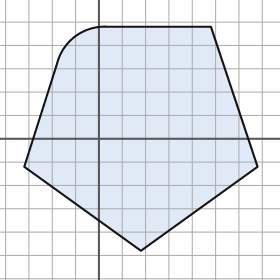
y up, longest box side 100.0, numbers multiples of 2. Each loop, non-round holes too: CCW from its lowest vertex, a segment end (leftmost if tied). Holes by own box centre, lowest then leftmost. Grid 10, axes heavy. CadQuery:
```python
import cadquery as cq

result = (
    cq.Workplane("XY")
    .moveTo(18.0, -48.0)
    .lineTo(68.0, -12.0)
    .lineTo(48.0, 48.0)
    .lineTo(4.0, 48.0)
    .threePointArc((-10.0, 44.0), (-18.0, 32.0))
    .lineTo(-32.0, -12.0)
    .close()
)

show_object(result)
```